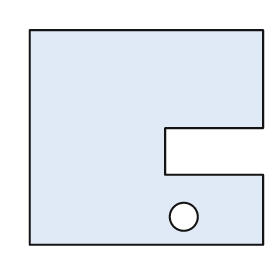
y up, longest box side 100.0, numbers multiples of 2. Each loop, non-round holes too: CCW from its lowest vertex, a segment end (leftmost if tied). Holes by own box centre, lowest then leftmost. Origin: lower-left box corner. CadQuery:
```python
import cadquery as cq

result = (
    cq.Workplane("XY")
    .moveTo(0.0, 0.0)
    .lineTo(100.0, 0.0)
    .lineTo(100.0, 30.0)
    .lineTo(58.0, 30.0)
    .lineTo(58.0, 50.0)
    .lineTo(100.0, 50.0)
    .lineTo(100.0, 92.0)
    .lineTo(0.0, 92.0)
    .close()
    .moveTo(66.0, 12.0)
    .circle(6.0)
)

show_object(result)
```